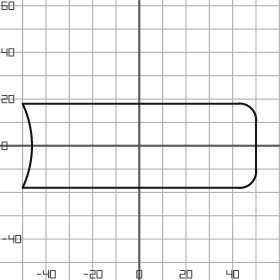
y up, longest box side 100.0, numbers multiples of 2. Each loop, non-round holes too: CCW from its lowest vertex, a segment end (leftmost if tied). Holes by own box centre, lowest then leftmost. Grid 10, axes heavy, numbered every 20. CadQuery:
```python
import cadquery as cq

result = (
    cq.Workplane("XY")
    .moveTo(-50.0, -18.0)
    .lineTo(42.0, -18.0)
    .threePointArc((48.0, -16.0), (50.0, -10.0))
    .lineTo(50.0, 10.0)
    .threePointArc((48.0, 16.0), (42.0, 18.0))
    .lineTo(-50.0, 18.0)
    .threePointArc((-46.0, 0.0), (-50.0, -18.0))
    .close()
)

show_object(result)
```